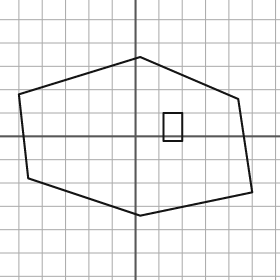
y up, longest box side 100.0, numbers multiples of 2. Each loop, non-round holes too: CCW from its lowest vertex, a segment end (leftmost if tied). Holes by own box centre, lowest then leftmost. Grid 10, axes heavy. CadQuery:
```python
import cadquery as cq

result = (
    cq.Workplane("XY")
    .moveTo(2.0, -34.0)
    .lineTo(50.0, -24.0)
    .lineTo(44.0, 16.0)
    .lineTo(2.0, 34.0)
    .lineTo(-50.0, 18.0)
    .lineTo(-46.0, -18.0)
    .close()
    .moveTo(12.0, -2.0)
    .lineTo(20.0, -2.0)
    .lineTo(20.0, 10.0)
    .lineTo(12.0, 10.0)
    .close()
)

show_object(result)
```